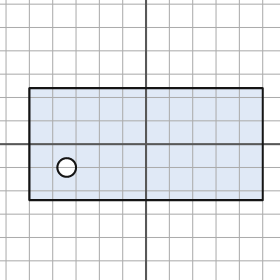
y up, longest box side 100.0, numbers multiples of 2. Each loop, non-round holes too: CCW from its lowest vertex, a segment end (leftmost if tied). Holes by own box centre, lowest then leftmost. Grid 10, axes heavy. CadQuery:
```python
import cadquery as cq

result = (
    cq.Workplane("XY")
    .moveTo(-50.0, -24.0)
    .lineTo(50.0, -24.0)
    .lineTo(50.0, 24.0)
    .lineTo(-50.0, 24.0)
    .close()
    .moveTo(-34.0, -10.0)
    .circle(4.0)
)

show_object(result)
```